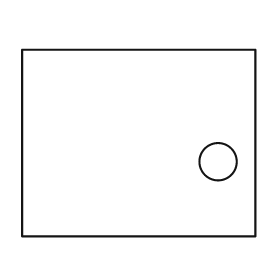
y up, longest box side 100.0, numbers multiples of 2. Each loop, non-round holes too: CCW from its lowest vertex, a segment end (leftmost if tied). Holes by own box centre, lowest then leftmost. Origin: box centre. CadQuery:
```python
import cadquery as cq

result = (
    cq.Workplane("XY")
    .moveTo(-50.0, -40.0)
    .lineTo(50.0, -40.0)
    .lineTo(50.0, 40.0)
    .lineTo(-50.0, 40.0)
    .close()
    .moveTo(34.0, -8.0)
    .circle(8.0)
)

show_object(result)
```